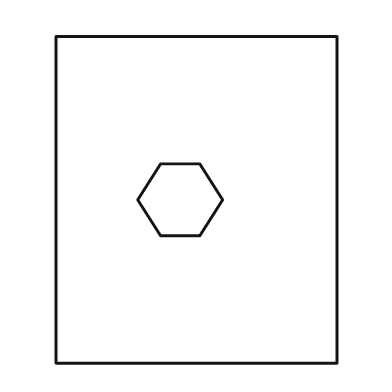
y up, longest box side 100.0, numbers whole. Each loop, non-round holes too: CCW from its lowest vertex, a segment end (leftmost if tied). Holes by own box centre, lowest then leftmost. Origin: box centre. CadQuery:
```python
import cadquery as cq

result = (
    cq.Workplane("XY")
    .moveTo(-43.0, -50.0)
    .lineTo(43.0, -50.0)
    .lineTo(43.0, 50.0)
    .lineTo(-43.0, 50.0)
    .close()
    .moveTo(-11.0, -11.0)
    .lineTo(1.0, -11.0)
    .lineTo(8.0, 0.0)
    .lineTo(1.0, 11.0)
    .lineTo(-11.0, 11.0)
    .lineTo(-18.0, 0.0)
    .close()
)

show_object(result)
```